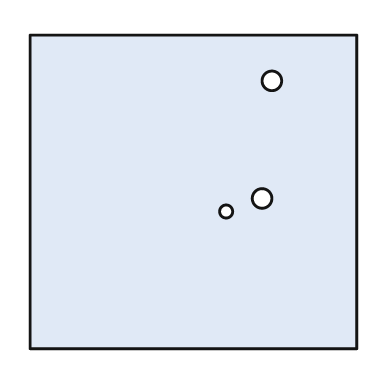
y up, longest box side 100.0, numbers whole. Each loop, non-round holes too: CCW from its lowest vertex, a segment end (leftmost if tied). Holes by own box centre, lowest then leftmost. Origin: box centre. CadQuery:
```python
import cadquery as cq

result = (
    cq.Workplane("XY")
    .moveTo(-50.0, -48.0)
    .lineTo(50.0, -48.0)
    .lineTo(50.0, 48.0)
    .lineTo(-50.0, 48.0)
    .close()
    .moveTo(10.0, -6.0)
    .circle(2.0)
    .moveTo(21.0, -2.0)
    .circle(3.0)
    .moveTo(24.0, 34.0)
    .circle(3.0)
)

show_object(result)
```